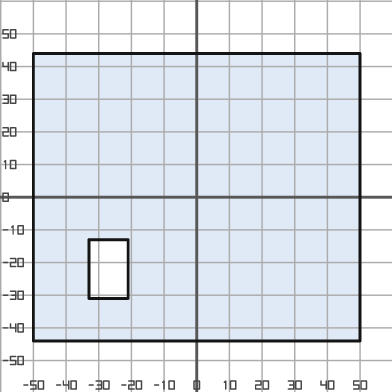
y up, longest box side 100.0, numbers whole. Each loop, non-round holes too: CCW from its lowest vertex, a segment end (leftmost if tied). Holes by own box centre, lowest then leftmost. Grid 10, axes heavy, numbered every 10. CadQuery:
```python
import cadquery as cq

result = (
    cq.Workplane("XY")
    .moveTo(-50.0, -44.0)
    .lineTo(50.0, -44.0)
    .lineTo(50.0, 44.0)
    .lineTo(-50.0, 44.0)
    .close()
    .moveTo(-33.0, -31.0)
    .lineTo(-21.0, -31.0)
    .lineTo(-21.0, -13.0)
    .lineTo(-33.0, -13.0)
    .close()
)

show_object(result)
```